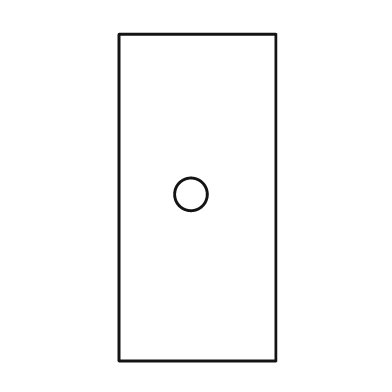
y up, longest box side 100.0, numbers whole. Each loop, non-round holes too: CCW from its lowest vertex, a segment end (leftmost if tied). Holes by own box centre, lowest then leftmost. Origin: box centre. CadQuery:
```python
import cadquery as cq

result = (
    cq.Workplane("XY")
    .moveTo(-24.0, -50.0)
    .lineTo(24.0, -50.0)
    .lineTo(24.0, 50.0)
    .lineTo(-24.0, 50.0)
    .close()
    .moveTo(-2.0, 1.0)
    .circle(5.0)
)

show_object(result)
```